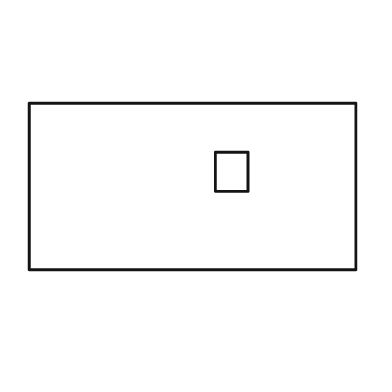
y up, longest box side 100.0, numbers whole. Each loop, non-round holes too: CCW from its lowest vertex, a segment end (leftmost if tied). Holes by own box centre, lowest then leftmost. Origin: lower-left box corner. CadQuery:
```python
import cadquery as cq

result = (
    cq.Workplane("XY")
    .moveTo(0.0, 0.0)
    .lineTo(100.0, 0.0)
    .lineTo(100.0, 51.0)
    .lineTo(0.0, 51.0)
    .close()
    .moveTo(57.0, 24.0)
    .lineTo(67.0, 24.0)
    .lineTo(67.0, 36.0)
    .lineTo(57.0, 36.0)
    .close()
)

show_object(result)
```